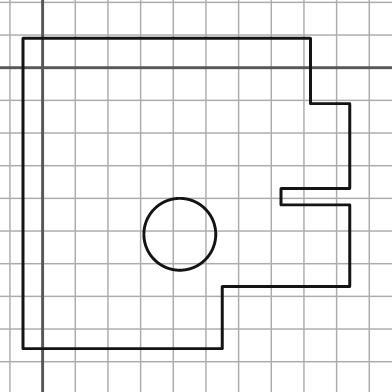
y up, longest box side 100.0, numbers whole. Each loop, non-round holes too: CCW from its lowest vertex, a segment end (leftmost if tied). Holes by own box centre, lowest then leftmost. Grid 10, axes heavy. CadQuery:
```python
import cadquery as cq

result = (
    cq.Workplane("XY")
    .moveTo(-6.0, -86.0)
    .lineTo(55.0, -86.0)
    .lineTo(55.0, -67.0)
    .lineTo(94.0, -67.0)
    .lineTo(94.0, -42.0)
    .lineTo(73.0, -42.0)
    .lineTo(73.0, -37.0)
    .lineTo(94.0, -37.0)
    .lineTo(94.0, -11.0)
    .lineTo(82.0, -11.0)
    .lineTo(82.0, 9.0)
    .lineTo(-6.0, 9.0)
    .close()
    .moveTo(42.0, -51.0)
    .circle(11.0)
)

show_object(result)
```